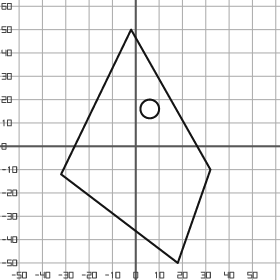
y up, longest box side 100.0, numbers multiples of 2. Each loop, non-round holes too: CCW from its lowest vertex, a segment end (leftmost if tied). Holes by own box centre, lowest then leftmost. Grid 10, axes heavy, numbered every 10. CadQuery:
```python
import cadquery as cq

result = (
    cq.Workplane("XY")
    .moveTo(18.0, -50.0)
    .lineTo(32.0, -10.0)
    .lineTo(-2.0, 50.0)
    .lineTo(-32.0, -12.0)
    .close()
    .moveTo(6.0, 16.0)
    .circle(4.0)
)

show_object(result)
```